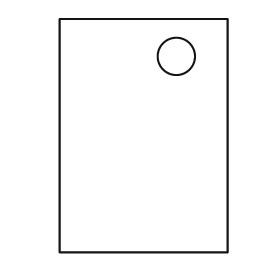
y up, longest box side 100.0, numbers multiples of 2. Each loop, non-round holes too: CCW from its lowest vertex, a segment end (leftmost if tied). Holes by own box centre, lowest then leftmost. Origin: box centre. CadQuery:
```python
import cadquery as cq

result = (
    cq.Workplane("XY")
    .moveTo(-36.0, -50.0)
    .lineTo(36.0, -50.0)
    .lineTo(36.0, 50.0)
    .lineTo(-36.0, 50.0)
    .close()
    .moveTo(14.0, 34.0)
    .circle(8.0)
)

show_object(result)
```